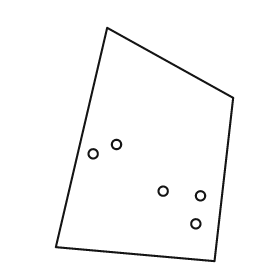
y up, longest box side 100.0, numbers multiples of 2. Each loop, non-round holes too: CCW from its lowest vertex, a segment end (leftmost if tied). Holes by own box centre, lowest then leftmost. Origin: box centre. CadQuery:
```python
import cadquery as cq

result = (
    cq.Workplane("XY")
    .moveTo(30.0, -50.0)
    .lineTo(38.0, 20.0)
    .lineTo(-16.0, 50.0)
    .lineTo(-38.0, -44.0)
    .close()
    .moveTo(22.0, -34.0)
    .circle(2.0)
    .moveTo(24.0, -22.0)
    .circle(2.0)
    .moveTo(8.0, -20.0)
    .circle(2.0)
    .moveTo(-22.0, -4.0)
    .circle(2.0)
    .moveTo(-12.0, 0.0)
    .circle(2.0)
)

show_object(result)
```